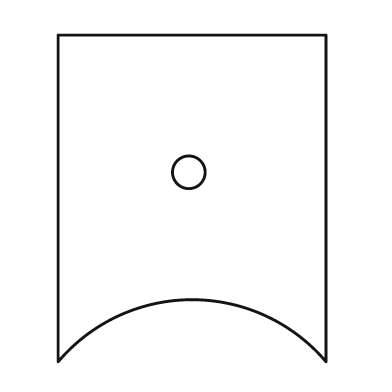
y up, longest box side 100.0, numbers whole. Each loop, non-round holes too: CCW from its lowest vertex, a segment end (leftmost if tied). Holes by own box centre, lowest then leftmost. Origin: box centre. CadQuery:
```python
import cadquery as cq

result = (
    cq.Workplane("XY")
    .moveTo(-41.0, -50.0)
    .threePointArc((0.0, -31.0), (41.0, -50.0))
    .lineTo(41.0, 50.0)
    .lineTo(-41.0, 50.0)
    .close()
    .moveTo(-1.0, 8.0)
    .circle(5.0)
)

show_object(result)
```